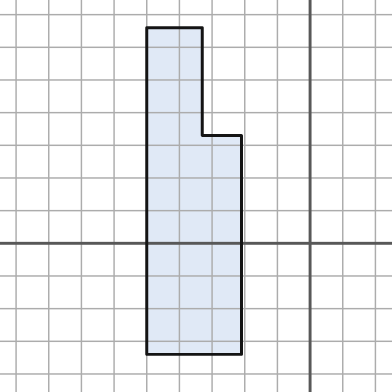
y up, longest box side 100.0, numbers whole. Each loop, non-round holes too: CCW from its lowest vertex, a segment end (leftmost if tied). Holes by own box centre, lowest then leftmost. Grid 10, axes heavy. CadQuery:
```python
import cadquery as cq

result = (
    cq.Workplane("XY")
    .moveTo(-50.0, -34.0)
    .lineTo(-21.0, -34.0)
    .lineTo(-21.0, 33.0)
    .lineTo(-33.0, 33.0)
    .lineTo(-33.0, 66.0)
    .lineTo(-50.0, 66.0)
    .close()
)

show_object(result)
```